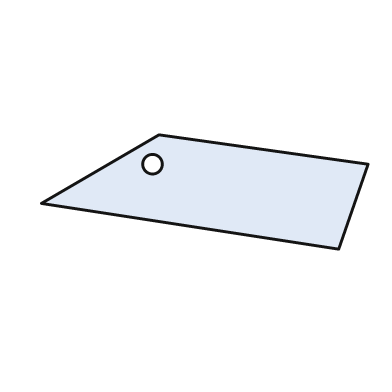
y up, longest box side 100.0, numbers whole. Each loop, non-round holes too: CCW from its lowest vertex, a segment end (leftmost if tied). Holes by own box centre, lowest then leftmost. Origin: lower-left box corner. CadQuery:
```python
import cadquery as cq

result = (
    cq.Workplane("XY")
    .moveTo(91.0, 0.0)
    .lineTo(100.0, 26.0)
    .lineTo(36.0, 35.0)
    .lineTo(0.0, 14.0)
    .close()
    .moveTo(34.0, 26.0)
    .circle(3.0)
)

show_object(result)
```